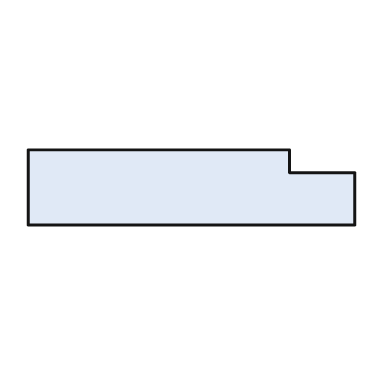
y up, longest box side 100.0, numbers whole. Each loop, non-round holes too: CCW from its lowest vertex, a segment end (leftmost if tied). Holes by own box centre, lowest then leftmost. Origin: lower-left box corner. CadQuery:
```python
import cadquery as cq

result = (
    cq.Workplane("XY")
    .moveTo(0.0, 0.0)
    .lineTo(100.0, 0.0)
    .lineTo(100.0, 16.0)
    .lineTo(80.0, 16.0)
    .lineTo(80.0, 23.0)
    .lineTo(0.0, 23.0)
    .close()
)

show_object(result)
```